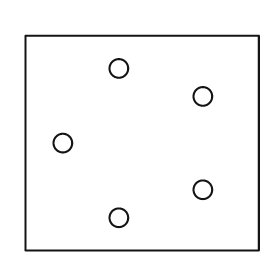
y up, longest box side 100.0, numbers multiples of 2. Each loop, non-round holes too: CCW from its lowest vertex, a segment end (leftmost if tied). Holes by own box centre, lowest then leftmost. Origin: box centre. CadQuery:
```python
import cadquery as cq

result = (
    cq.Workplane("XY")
    .moveTo(-50.0, -46.0)
    .lineTo(50.0, -46.0)
    .lineTo(50.0, 46.0)
    .lineTo(-50.0, 46.0)
    .close()
    .moveTo(-10.0, -32.0)
    .circle(4.0)
    .moveTo(26.0, -20.0)
    .circle(4.0)
    .moveTo(-34.0, 0.0)
    .circle(4.0)
    .moveTo(26.0, 20.0)
    .circle(4.0)
    .moveTo(-10.0, 32.0)
    .circle(4.0)
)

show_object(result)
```